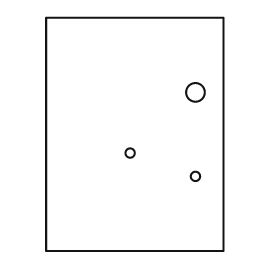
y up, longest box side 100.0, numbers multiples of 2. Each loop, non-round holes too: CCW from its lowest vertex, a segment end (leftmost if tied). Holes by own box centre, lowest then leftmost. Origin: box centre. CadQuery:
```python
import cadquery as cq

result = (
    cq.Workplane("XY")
    .moveTo(-38.0, -50.0)
    .lineTo(38.0, -50.0)
    .lineTo(38.0, 50.0)
    .lineTo(-38.0, 50.0)
    .close()
    .moveTo(26.0, -18.0)
    .circle(2.0)
    .moveTo(-2.0, -8.0)
    .circle(2.0)
    .moveTo(26.0, 18.0)
    .circle(4.0)
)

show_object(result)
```